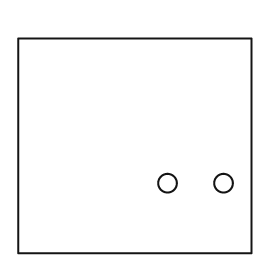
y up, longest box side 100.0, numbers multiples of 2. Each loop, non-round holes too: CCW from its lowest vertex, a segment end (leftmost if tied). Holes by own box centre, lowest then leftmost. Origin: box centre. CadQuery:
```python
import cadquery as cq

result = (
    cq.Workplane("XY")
    .moveTo(-50.0, -46.0)
    .lineTo(50.0, -46.0)
    .lineTo(50.0, 46.0)
    .lineTo(-50.0, 46.0)
    .close()
    .moveTo(14.0, -16.0)
    .circle(4.0)
    .moveTo(38.0, -16.0)
    .circle(4.0)
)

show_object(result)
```